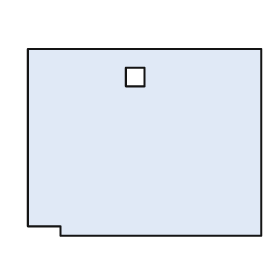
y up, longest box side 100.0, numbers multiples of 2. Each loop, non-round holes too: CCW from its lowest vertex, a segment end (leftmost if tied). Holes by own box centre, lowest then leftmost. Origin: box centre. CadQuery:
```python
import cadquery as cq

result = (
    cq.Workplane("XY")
    .moveTo(-36.0, -40.0)
    .lineTo(50.0, -40.0)
    .lineTo(50.0, 40.0)
    .lineTo(-50.0, 40.0)
    .lineTo(-50.0, -36.0)
    .lineTo(-36.0, -36.0)
    .close()
    .moveTo(-8.0, 24.0)
    .lineTo(0.0, 24.0)
    .lineTo(0.0, 32.0)
    .lineTo(-8.0, 32.0)
    .close()
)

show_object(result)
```